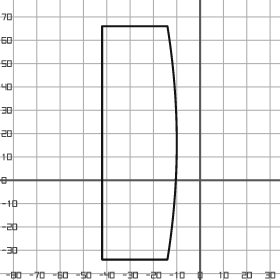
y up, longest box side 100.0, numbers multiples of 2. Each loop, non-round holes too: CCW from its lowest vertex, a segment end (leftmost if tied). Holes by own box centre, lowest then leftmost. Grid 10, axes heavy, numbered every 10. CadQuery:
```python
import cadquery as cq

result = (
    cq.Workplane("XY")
    .moveTo(-42.0, -34.0)
    .lineTo(-14.0, -34.0)
    .threePointArc((-10.0, 16.0), (-14.0, 66.0))
    .lineTo(-42.0, 66.0)
    .close()
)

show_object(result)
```